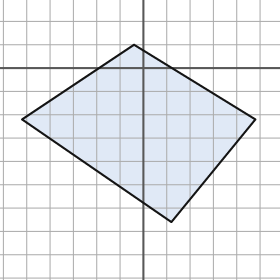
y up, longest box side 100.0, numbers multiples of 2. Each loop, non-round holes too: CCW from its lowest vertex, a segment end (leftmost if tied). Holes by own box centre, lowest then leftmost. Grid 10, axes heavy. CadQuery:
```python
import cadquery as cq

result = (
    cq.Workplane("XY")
    .moveTo(12.0, -66.0)
    .lineTo(48.0, -22.0)
    .lineTo(-4.0, 10.0)
    .lineTo(-52.0, -22.0)
    .close()
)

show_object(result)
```